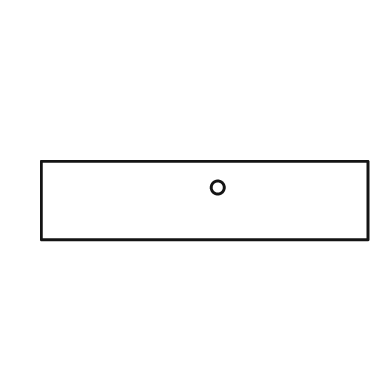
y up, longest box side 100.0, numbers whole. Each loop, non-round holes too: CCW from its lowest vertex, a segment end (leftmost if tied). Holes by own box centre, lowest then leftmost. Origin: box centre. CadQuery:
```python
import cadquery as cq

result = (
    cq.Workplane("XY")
    .moveTo(-50.0, -12.0)
    .lineTo(50.0, -12.0)
    .lineTo(50.0, 12.0)
    .lineTo(-50.0, 12.0)
    .close()
    .moveTo(4.0, 4.0)
    .circle(2.0)
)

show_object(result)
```